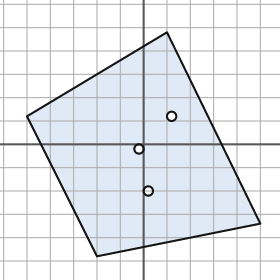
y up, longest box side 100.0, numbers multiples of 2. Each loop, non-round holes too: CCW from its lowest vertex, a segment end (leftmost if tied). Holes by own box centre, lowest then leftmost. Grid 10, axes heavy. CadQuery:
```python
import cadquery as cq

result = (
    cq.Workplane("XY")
    .moveTo(-20.0, -48.0)
    .lineTo(50.0, -34.0)
    .lineTo(10.0, 48.0)
    .lineTo(-50.0, 12.0)
    .close()
    .moveTo(2.0, -20.0)
    .circle(2.0)
    .moveTo(-2.0, -2.0)
    .circle(2.0)
    .moveTo(12.0, 12.0)
    .circle(2.0)
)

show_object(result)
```